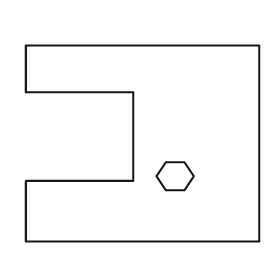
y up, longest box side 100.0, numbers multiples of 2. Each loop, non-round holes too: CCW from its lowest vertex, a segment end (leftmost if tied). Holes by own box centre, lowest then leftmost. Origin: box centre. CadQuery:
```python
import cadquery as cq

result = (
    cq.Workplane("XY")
    .moveTo(-50.0, -42.0)
    .lineTo(50.0, -42.0)
    .lineTo(50.0, 42.0)
    .lineTo(-50.0, 42.0)
    .lineTo(-50.0, 22.0)
    .lineTo(-4.0, 22.0)
    .lineTo(-4.0, -16.0)
    .lineTo(-50.0, -16.0)
    .close()
    .moveTo(10.0, -20.0)
    .lineTo(18.0, -20.0)
    .lineTo(22.0, -14.0)
    .lineTo(18.0, -8.0)
    .lineTo(10.0, -8.0)
    .lineTo(6.0, -14.0)
    .close()
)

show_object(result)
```